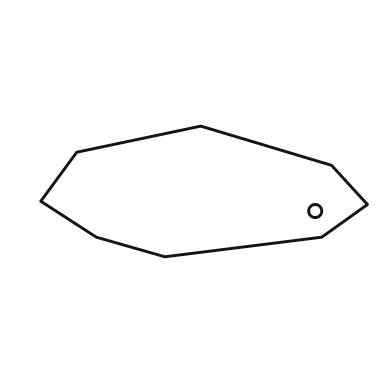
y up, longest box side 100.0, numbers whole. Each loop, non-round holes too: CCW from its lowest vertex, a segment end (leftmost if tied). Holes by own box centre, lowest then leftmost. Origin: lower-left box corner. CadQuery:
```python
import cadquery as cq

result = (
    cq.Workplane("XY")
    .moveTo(38.0, 0.0)
    .lineTo(86.0, 6.0)
    .lineTo(100.0, 16.0)
    .lineTo(89.0, 28.0)
    .lineTo(49.0, 40.0)
    .lineTo(11.0, 32.0)
    .lineTo(0.0, 17.0)
    .lineTo(17.0, 6.0)
    .close()
    .moveTo(84.0, 14.0)
    .circle(2.0)
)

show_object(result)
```